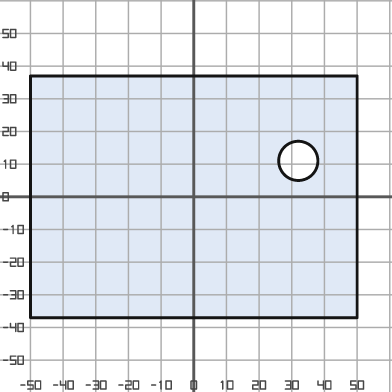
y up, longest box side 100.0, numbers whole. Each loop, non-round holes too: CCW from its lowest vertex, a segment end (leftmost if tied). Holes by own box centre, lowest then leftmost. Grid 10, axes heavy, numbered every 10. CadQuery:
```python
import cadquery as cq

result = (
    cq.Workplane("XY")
    .moveTo(-50.0, -37.0)
    .lineTo(50.0, -37.0)
    .lineTo(50.0, 37.0)
    .lineTo(-50.0, 37.0)
    .close()
    .moveTo(32.0, 11.0)
    .circle(6.0)
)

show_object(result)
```